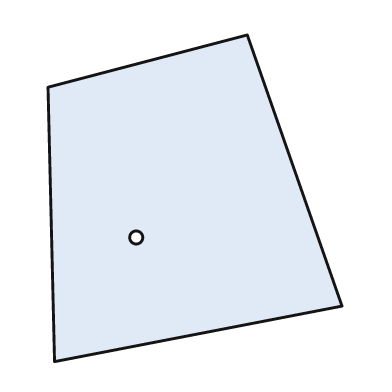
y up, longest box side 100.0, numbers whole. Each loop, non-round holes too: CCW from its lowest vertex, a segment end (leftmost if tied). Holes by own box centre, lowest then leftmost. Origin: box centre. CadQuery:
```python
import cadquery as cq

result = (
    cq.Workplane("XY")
    .moveTo(-43.0, -50.0)
    .lineTo(45.0, -33.0)
    .lineTo(16.0, 50.0)
    .lineTo(-45.0, 34.0)
    .close()
    .moveTo(-18.0, -12.0)
    .circle(2.0)
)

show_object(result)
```